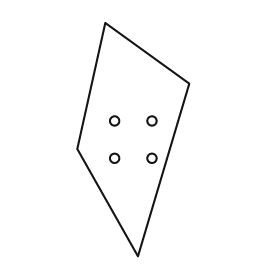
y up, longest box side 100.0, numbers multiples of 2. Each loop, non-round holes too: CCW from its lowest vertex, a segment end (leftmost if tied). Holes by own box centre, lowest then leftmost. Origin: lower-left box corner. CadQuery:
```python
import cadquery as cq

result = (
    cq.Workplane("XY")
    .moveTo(26.0, 0.0)
    .lineTo(48.0, 74.0)
    .lineTo(12.0, 100.0)
    .lineTo(0.0, 46.0)
    .close()
    .moveTo(16.0, 42.0)
    .circle(2.0)
    .moveTo(32.0, 42.0)
    .circle(2.0)
    .moveTo(16.0, 58.0)
    .circle(2.0)
    .moveTo(32.0, 58.0)
    .circle(2.0)
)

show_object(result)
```